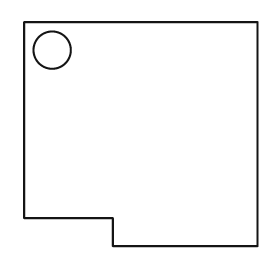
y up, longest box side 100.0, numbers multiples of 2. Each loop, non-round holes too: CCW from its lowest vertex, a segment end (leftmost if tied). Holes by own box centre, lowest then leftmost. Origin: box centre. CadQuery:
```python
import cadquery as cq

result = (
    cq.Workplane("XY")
    .moveTo(-12.0, -48.0)
    .lineTo(50.0, -48.0)
    .lineTo(50.0, 48.0)
    .lineTo(-50.0, 48.0)
    .lineTo(-50.0, -36.0)
    .lineTo(-12.0, -36.0)
    .close()
    .moveTo(-38.0, 36.0)
    .circle(8.0)
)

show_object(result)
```